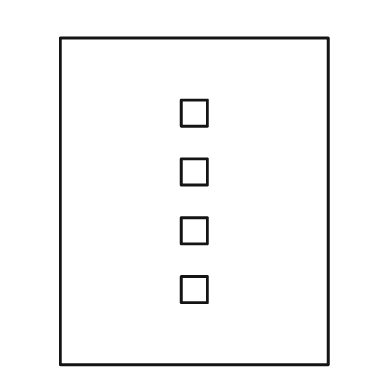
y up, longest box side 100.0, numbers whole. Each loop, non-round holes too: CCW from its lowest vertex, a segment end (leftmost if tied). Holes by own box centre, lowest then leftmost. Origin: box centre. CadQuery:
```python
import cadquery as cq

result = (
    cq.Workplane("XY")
    .moveTo(-41.0, -50.0)
    .lineTo(41.0, -50.0)
    .lineTo(41.0, 50.0)
    .lineTo(-41.0, 50.0)
    .close()
    .moveTo(-4.0, -31.0)
    .lineTo(4.0, -31.0)
    .lineTo(4.0, -23.0)
    .lineTo(-4.0, -23.0)
    .close()
    .moveTo(-4.0, -13.0)
    .lineTo(4.0, -13.0)
    .lineTo(4.0, -5.0)
    .lineTo(-4.0, -5.0)
    .close()
    .moveTo(-4.0, 5.0)
    .lineTo(4.0, 5.0)
    .lineTo(4.0, 13.0)
    .lineTo(-4.0, 13.0)
    .close()
    .moveTo(-4.0, 23.0)
    .lineTo(4.0, 23.0)
    .lineTo(4.0, 31.0)
    .lineTo(-4.0, 31.0)
    .close()
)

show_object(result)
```